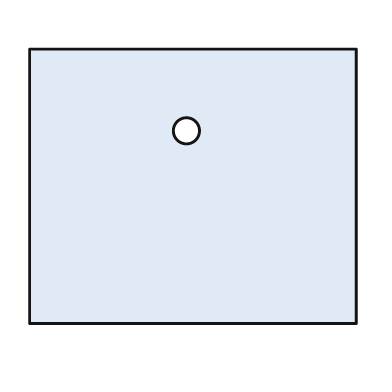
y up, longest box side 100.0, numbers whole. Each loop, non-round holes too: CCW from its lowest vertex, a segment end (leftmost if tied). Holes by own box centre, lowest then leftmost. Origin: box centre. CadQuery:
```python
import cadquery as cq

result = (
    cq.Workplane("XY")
    .moveTo(-50.0, -42.0)
    .lineTo(50.0, -42.0)
    .lineTo(50.0, 42.0)
    .lineTo(-50.0, 42.0)
    .close()
    .moveTo(-2.0, 17.0)
    .circle(4.0)
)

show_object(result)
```